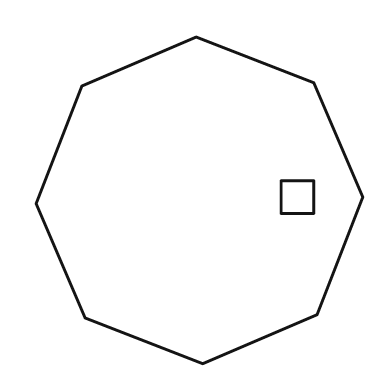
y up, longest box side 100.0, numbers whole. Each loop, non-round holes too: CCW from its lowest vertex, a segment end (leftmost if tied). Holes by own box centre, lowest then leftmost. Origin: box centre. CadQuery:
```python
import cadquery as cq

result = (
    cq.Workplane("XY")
    .moveTo(1.0, -50.0)
    .lineTo(36.0, -35.0)
    .lineTo(50.0, 1.0)
    .lineTo(35.0, 36.0)
    .lineTo(-1.0, 50.0)
    .lineTo(-36.0, 35.0)
    .lineTo(-50.0, -1.0)
    .lineTo(-35.0, -36.0)
    .close()
    .moveTo(25.0, -4.0)
    .lineTo(35.0, -4.0)
    .lineTo(35.0, 6.0)
    .lineTo(25.0, 6.0)
    .close()
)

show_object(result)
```